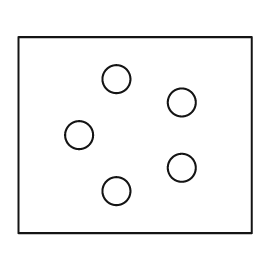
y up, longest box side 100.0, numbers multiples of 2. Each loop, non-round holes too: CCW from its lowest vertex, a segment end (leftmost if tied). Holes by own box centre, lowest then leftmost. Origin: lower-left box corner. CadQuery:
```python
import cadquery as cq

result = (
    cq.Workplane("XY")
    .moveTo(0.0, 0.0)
    .lineTo(100.0, 0.0)
    .lineTo(100.0, 84.0)
    .lineTo(0.0, 84.0)
    .close()
    .moveTo(42.0, 18.0)
    .circle(6.0)
    .moveTo(70.0, 28.0)
    .circle(6.0)
    .moveTo(26.0, 42.0)
    .circle(6.0)
    .moveTo(70.0, 56.0)
    .circle(6.0)
    .moveTo(42.0, 66.0)
    .circle(6.0)
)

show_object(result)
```